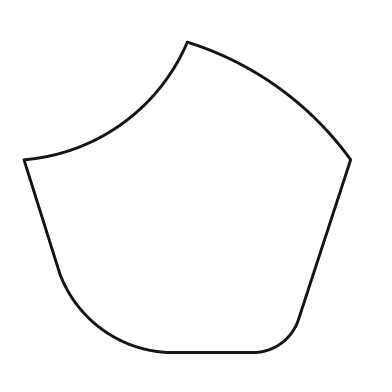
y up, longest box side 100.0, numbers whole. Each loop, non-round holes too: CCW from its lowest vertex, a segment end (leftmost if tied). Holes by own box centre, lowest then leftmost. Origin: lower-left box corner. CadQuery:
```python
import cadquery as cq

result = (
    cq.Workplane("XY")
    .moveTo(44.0, 0.0)
    .lineTo(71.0, 0.0)
    .threePointArc((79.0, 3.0), (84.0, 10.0))
    .lineTo(100.0, 59.0)
    .threePointArc((78.0, 81.0), (50.0, 95.0))
    .threePointArc((30.0, 70.0), (0.0, 59.0))
    .lineTo(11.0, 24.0)
    .threePointArc((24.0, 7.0), (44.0, 0.0))
    .close()
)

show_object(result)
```